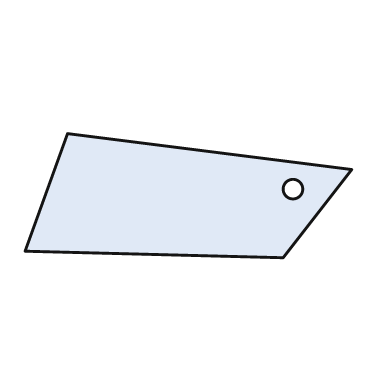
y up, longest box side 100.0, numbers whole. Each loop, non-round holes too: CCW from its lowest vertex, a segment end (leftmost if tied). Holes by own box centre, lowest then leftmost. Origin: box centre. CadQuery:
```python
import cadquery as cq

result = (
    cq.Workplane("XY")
    .moveTo(29.0, -19.0)
    .lineTo(50.0, 8.0)
    .lineTo(-37.0, 19.0)
    .lineTo(-50.0, -17.0)
    .close()
    .moveTo(32.0, 2.0)
    .circle(3.0)
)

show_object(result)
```